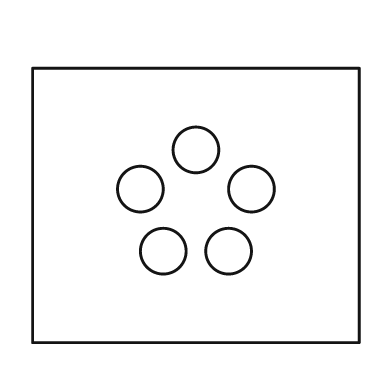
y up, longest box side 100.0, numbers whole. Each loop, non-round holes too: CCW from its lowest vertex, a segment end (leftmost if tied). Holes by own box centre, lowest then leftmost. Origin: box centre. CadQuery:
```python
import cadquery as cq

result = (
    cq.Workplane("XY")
    .moveTo(-50.0, -42.0)
    .lineTo(50.0, -42.0)
    .lineTo(50.0, 42.0)
    .lineTo(-50.0, 42.0)
    .close()
    .moveTo(-10.0, -14.0)
    .circle(7.0)
    .moveTo(10.0, -14.0)
    .circle(7.0)
    .moveTo(-17.0, 5.0)
    .circle(7.0)
    .moveTo(17.0, 5.0)
    .circle(7.0)
    .moveTo(0.0, 17.0)
    .circle(7.0)
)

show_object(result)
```